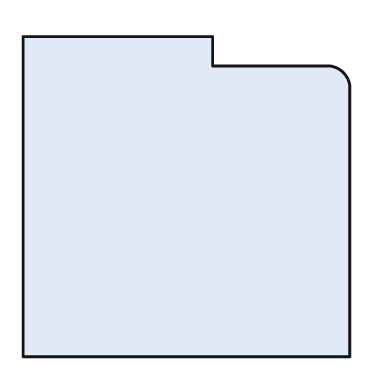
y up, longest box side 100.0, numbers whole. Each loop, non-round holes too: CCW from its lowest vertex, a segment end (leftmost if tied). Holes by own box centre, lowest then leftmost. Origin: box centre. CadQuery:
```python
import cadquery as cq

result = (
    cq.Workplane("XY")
    .moveTo(-50.0, -49.0)
    .lineTo(50.0, -49.0)
    .lineTo(50.0, 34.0)
    .threePointArc((48.0, 38.0), (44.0, 40.0))
    .lineTo(8.0, 40.0)
    .lineTo(8.0, 49.0)
    .lineTo(-50.0, 49.0)
    .close()
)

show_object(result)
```